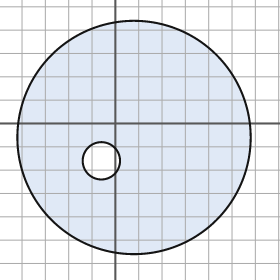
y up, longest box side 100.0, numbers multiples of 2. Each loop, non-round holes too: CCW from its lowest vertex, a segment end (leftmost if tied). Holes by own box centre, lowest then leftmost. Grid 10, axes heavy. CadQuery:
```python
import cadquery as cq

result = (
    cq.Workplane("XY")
    .moveTo(8.0, -6.0)
    .circle(50.0)
    .moveTo(-6.0, -16.0)
    .circle(8.0)
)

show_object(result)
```